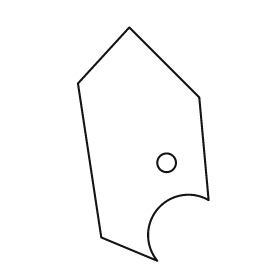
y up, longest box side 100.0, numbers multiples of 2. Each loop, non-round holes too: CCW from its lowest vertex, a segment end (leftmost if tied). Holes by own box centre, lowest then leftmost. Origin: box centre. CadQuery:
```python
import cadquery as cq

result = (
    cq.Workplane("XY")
    .moveTo(6.0, -50.0)
    .threePointArc((6.0, -28.0), (28.0, -24.0))
    .lineTo(24.0, 20.0)
    .lineTo(-6.0, 50.0)
    .lineTo(-28.0, 26.0)
    .lineTo(-18.0, -40.0)
    .close()
    .moveTo(10.0, -8.0)
    .circle(4.0)
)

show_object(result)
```